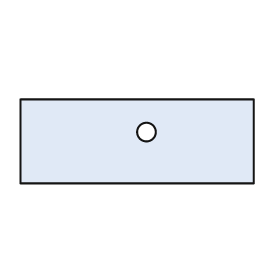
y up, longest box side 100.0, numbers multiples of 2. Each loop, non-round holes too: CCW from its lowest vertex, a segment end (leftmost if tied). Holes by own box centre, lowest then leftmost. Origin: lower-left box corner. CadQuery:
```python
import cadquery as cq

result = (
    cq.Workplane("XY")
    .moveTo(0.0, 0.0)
    .lineTo(100.0, 0.0)
    .lineTo(100.0, 36.0)
    .lineTo(0.0, 36.0)
    .close()
    .moveTo(54.0, 22.0)
    .circle(4.0)
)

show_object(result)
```